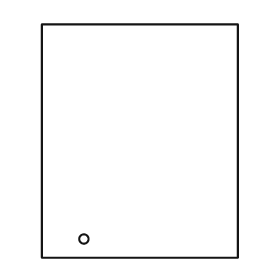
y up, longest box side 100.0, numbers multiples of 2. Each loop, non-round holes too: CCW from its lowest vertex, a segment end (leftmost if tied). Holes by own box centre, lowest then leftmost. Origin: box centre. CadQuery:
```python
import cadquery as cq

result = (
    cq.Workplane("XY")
    .moveTo(-42.0, -50.0)
    .lineTo(42.0, -50.0)
    .lineTo(42.0, 50.0)
    .lineTo(-42.0, 50.0)
    .close()
    .moveTo(-24.0, -42.0)
    .circle(2.0)
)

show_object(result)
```